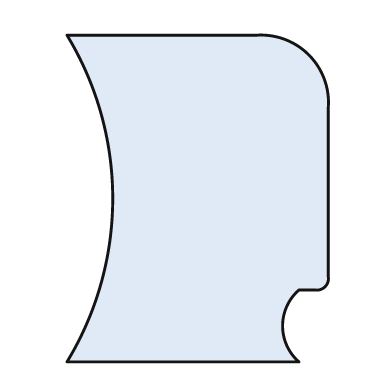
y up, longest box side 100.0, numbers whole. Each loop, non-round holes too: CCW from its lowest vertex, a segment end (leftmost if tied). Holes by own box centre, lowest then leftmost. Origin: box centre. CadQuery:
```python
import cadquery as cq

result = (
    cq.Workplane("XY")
    .moveTo(-40.0, -50.0)
    .lineTo(31.0, -50.0)
    .threePointArc((26.0, -39.0), (31.0, -28.0))
    .lineTo(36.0, -28.0)
    .threePointArc((39.0, -27.0), (40.0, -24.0))
    .lineTo(40.0, 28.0)
    .threePointArc((34.0, 44.0), (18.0, 50.0))
    .lineTo(-40.0, 50.0)
    .threePointArc((-26.0, 0.0), (-40.0, -50.0))
    .close()
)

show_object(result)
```